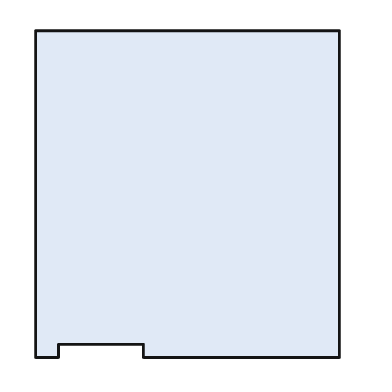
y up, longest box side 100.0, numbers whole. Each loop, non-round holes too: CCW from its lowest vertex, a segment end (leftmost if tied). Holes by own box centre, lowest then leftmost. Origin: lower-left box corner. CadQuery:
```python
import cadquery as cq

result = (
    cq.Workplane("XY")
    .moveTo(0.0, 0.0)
    .lineTo(7.0, 0.0)
    .lineTo(7.0, 4.0)
    .lineTo(33.0, 4.0)
    .lineTo(33.0, 0.0)
    .lineTo(93.0, 0.0)
    .lineTo(93.0, 100.0)
    .lineTo(0.0, 100.0)
    .close()
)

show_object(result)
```